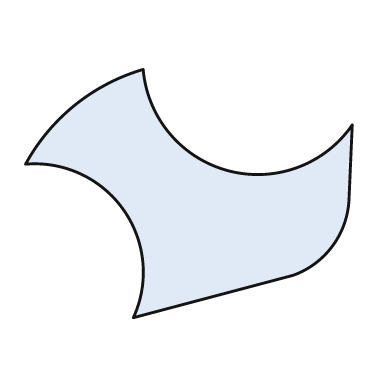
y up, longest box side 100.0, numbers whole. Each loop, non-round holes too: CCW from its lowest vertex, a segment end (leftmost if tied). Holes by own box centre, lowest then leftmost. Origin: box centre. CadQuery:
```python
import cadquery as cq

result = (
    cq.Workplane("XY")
    .moveTo(-17.0, -38.0)
    .lineTo(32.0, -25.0)
    .threePointArc((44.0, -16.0), (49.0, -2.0))
    .lineTo(50.0, 21.0)
    .threePointArc((12.0, 7.0), (-14.0, 38.0))
    .threePointArc((-35.0, 27.0), (-50.0, 9.0))
    .threePointArc((-20.0, -5.0), (-17.0, -38.0))
    .close()
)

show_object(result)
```